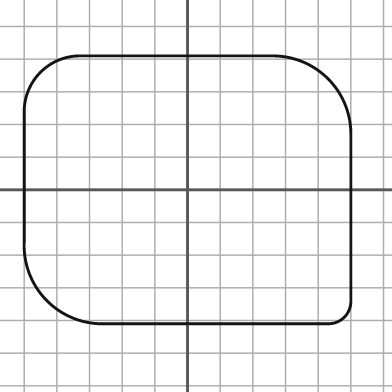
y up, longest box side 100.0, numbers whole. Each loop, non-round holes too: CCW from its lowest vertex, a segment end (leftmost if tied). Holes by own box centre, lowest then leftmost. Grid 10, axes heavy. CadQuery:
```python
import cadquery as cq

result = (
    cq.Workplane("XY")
    .moveTo(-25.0, -41.0)
    .lineTo(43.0, -41.0)
    .threePointArc((48.0, -39.0), (50.0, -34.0))
    .lineTo(50.0, 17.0)
    .threePointArc((43.0, 34.0), (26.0, 41.0))
    .lineTo(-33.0, 41.0)
    .threePointArc((-45.0, 36.0), (-50.0, 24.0))
    .lineTo(-50.0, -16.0)
    .threePointArc((-43.0, -34.0), (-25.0, -41.0))
    .close()
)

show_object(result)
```